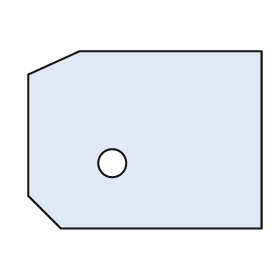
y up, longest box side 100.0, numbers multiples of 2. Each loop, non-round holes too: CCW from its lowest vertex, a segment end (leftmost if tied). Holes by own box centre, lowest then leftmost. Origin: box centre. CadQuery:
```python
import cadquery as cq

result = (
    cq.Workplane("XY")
    .moveTo(-36.0, -38.0)
    .lineTo(50.0, -38.0)
    .lineTo(50.0, 38.0)
    .lineTo(-28.0, 38.0)
    .lineTo(-50.0, 28.0)
    .lineTo(-50.0, -24.0)
    .close()
    .moveTo(-14.0, -10.0)
    .circle(6.0)
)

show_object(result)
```